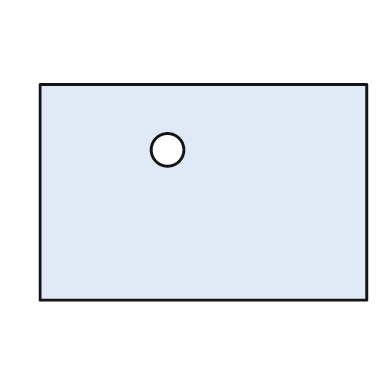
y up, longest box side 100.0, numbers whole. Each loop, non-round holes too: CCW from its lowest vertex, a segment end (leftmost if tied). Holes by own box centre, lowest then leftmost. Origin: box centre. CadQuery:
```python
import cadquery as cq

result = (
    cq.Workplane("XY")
    .moveTo(-50.0, -33.0)
    .lineTo(50.0, -33.0)
    .lineTo(50.0, 33.0)
    .lineTo(-50.0, 33.0)
    .close()
    .moveTo(-11.0, 13.0)
    .circle(5.0)
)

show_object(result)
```